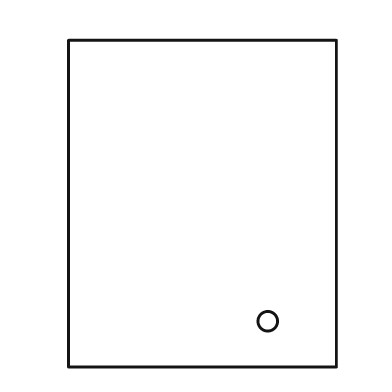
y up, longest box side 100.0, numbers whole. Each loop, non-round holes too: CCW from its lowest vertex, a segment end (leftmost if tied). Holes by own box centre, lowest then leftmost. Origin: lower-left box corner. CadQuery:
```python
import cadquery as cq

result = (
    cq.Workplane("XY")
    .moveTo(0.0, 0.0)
    .lineTo(82.0, 0.0)
    .lineTo(82.0, 100.0)
    .lineTo(0.0, 100.0)
    .close()
    .moveTo(61.0, 14.0)
    .circle(3.0)
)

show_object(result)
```